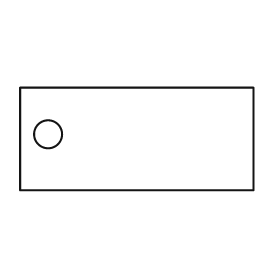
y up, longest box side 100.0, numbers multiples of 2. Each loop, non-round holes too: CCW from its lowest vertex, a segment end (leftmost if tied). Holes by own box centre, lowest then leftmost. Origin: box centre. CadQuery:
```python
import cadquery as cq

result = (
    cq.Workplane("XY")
    .moveTo(-50.0, -22.0)
    .lineTo(50.0, -22.0)
    .lineTo(50.0, 22.0)
    .lineTo(-50.0, 22.0)
    .close()
    .moveTo(-38.0, 2.0)
    .circle(6.0)
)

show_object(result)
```